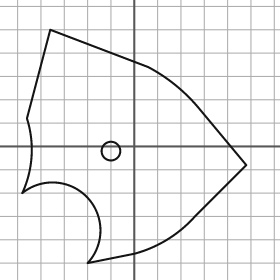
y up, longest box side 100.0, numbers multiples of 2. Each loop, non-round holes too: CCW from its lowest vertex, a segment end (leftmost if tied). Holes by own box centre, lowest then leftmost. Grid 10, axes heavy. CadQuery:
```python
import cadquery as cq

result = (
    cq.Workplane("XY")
    .moveTo(-20.0, -50.0)
    .lineTo(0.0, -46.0)
    .threePointArc((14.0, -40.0), (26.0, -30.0))
    .lineTo(48.0, -8.0)
    .lineTo(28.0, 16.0)
    .threePointArc((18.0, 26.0), (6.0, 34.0))
    .lineTo(-36.0, 50.0)
    .lineTo(-46.0, 12.0)
    .threePointArc((-44.0, -4.0), (-48.0, -20.0))
    .threePointArc((-20.0, -22.0), (-20.0, -50.0))
    .close()
    .moveTo(-10.0, -2.0)
    .circle(4.0)
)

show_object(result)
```